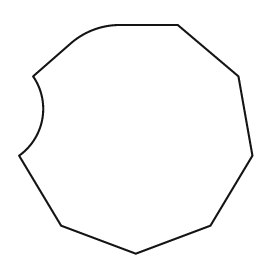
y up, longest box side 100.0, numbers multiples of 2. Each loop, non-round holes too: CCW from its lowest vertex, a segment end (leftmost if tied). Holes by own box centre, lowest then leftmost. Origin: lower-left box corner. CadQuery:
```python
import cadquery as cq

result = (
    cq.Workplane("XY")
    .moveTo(50.0, 0.0)
    .lineTo(82.0, 12.0)
    .lineTo(100.0, 42.0)
    .lineTo(94.0, 76.0)
    .lineTo(68.0, 98.0)
    .lineTo(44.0, 98.0)
    .threePointArc((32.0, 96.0), (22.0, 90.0))
    .lineTo(6.0, 76.0)
    .threePointArc((10.0, 58.0), (0.0, 42.0))
    .lineTo(18.0, 12.0)
    .close()
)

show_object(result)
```